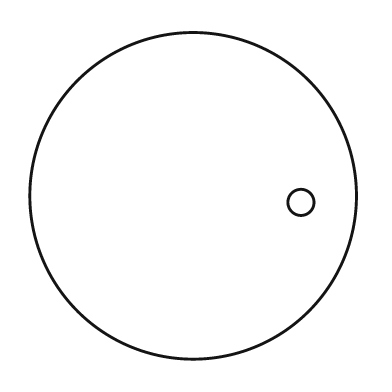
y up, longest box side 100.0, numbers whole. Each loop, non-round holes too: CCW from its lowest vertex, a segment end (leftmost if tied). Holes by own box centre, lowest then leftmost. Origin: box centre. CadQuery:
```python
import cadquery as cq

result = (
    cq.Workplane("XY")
    .moveTo(0.0, 0.0)
    .circle(50.0)
    .moveTo(33.0, -2.0)
    .circle(4.0)
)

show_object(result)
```